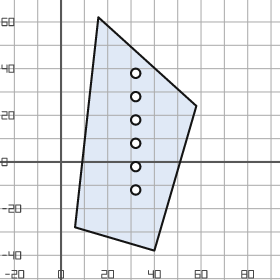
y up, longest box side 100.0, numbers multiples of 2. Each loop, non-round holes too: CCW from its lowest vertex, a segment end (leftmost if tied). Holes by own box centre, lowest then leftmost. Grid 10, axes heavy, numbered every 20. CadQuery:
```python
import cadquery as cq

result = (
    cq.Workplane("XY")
    .moveTo(40.0, -38.0)
    .lineTo(58.0, 24.0)
    .lineTo(16.0, 62.0)
    .lineTo(6.0, -28.0)
    .close()
    .moveTo(32.0, -12.0)
    .circle(2.0)
    .moveTo(32.0, -2.0)
    .circle(2.0)
    .moveTo(32.0, 8.0)
    .circle(2.0)
    .moveTo(32.0, 18.0)
    .circle(2.0)
    .moveTo(32.0, 28.0)
    .circle(2.0)
    .moveTo(32.0, 38.0)
    .circle(2.0)
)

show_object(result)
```